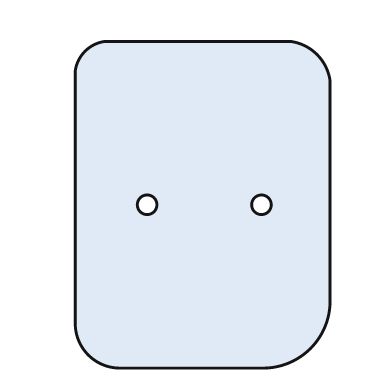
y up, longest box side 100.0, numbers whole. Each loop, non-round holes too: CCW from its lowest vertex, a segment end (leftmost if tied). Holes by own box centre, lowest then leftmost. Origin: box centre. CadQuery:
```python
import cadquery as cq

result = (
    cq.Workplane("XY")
    .moveTo(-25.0, -50.0)
    .lineTo(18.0, -50.0)
    .threePointArc((33.0, -44.0), (39.0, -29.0))
    .lineTo(39.0, 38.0)
    .threePointArc((35.0, 46.0), (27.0, 50.0))
    .lineTo(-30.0, 50.0)
    .threePointArc((-36.0, 47.0), (-39.0, 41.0))
    .lineTo(-39.0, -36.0)
    .threePointArc((-35.0, -46.0), (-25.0, -50.0))
    .close()
    .moveTo(-17.0, 0.0)
    .circle(3.0)
    .moveTo(18.0, 0.0)
    .circle(3.0)
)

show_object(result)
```